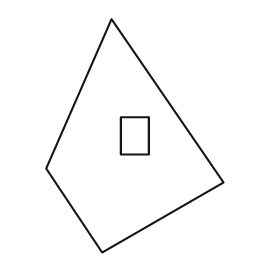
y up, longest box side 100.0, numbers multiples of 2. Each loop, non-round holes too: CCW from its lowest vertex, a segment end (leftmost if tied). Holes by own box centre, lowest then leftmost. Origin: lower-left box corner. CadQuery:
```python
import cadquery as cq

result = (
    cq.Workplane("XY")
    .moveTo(24.0, 0.0)
    .lineTo(76.0, 30.0)
    .lineTo(28.0, 100.0)
    .lineTo(0.0, 36.0)
    .close()
    .moveTo(32.0, 42.0)
    .lineTo(44.0, 42.0)
    .lineTo(44.0, 58.0)
    .lineTo(32.0, 58.0)
    .close()
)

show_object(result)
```